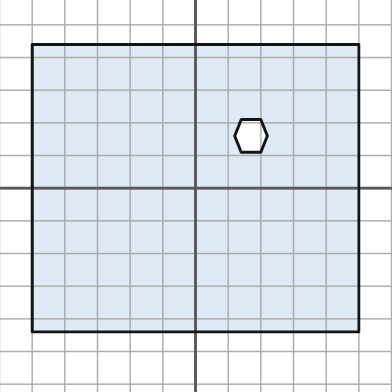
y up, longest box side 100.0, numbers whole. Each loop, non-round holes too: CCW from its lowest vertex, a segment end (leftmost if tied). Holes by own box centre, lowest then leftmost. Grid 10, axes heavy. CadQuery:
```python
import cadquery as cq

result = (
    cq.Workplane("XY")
    .moveTo(-50.0, -44.0)
    .lineTo(50.0, -44.0)
    .lineTo(50.0, 44.0)
    .lineTo(-50.0, 44.0)
    .close()
    .moveTo(14.0, 11.0)
    .lineTo(20.0, 11.0)
    .lineTo(22.0, 16.0)
    .lineTo(20.0, 21.0)
    .lineTo(14.0, 21.0)
    .lineTo(12.0, 16.0)
    .close()
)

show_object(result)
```